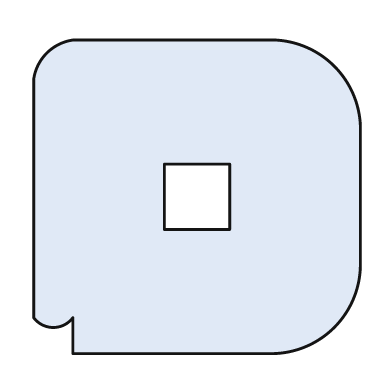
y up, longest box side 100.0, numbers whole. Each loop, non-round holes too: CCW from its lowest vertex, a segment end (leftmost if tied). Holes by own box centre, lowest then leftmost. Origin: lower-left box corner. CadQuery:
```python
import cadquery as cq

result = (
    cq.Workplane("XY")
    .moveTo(12.0, 0.0)
    .lineTo(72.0, 0.0)
    .threePointArc((92.0, 8.0), (100.0, 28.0))
    .lineTo(100.0, 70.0)
    .threePointArc((92.0, 88.0), (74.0, 96.0))
    .lineTo(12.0, 96.0)
    .threePointArc((4.0, 92.0), (0.0, 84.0))
    .lineTo(0.0, 11.0)
    .threePointArc((6.0, 8.0), (12.0, 11.0))
    .close()
    .moveTo(40.0, 38.0)
    .lineTo(60.0, 38.0)
    .lineTo(60.0, 58.0)
    .lineTo(40.0, 58.0)
    .close()
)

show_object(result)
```